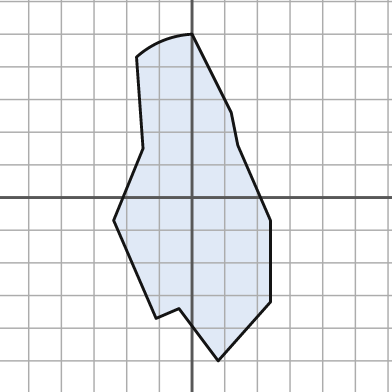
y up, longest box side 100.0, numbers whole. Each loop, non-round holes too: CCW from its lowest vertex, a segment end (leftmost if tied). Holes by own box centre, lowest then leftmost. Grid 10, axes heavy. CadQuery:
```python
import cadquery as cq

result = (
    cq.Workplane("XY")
    .moveTo(8.0, -50.0)
    .lineTo(24.0, -32.0)
    .lineTo(24.0, -7.0)
    .lineTo(14.0, 16.0)
    .lineTo(12.0, 26.0)
    .lineTo(0.0, 50.0)
    .threePointArc((-9.0, 48.0), (-17.0, 43.0))
    .lineTo(-15.0, 15.0)
    .lineTo(-24.0, -7.0)
    .lineTo(-11.0, -37.0)
    .lineTo(-4.0, -34.0)
    .close()
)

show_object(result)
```